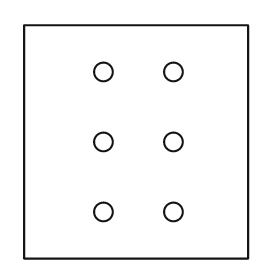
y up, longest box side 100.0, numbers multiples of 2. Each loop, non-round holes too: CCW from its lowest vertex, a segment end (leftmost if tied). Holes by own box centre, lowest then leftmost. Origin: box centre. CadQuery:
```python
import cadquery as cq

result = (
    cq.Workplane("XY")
    .moveTo(-48.0, -50.0)
    .lineTo(48.0, -50.0)
    .lineTo(48.0, 50.0)
    .lineTo(-48.0, 50.0)
    .close()
    .moveTo(-14.0, -30.0)
    .circle(4.0)
    .moveTo(16.0, -30.0)
    .circle(4.0)
    .moveTo(-14.0, 0.0)
    .circle(4.0)
    .moveTo(16.0, 0.0)
    .circle(4.0)
    .moveTo(-14.0, 30.0)
    .circle(4.0)
    .moveTo(16.0, 30.0)
    .circle(4.0)
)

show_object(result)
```